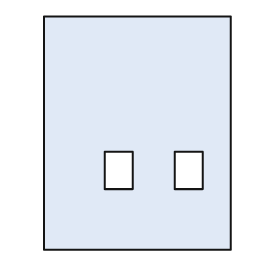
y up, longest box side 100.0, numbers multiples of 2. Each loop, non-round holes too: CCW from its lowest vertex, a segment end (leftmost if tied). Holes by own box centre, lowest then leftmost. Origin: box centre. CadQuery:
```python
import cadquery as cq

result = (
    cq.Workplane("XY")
    .moveTo(-40.0, -50.0)
    .lineTo(40.0, -50.0)
    .lineTo(40.0, 50.0)
    .lineTo(-40.0, 50.0)
    .close()
    .moveTo(-14.0, -24.0)
    .lineTo(-2.0, -24.0)
    .lineTo(-2.0, -8.0)
    .lineTo(-14.0, -8.0)
    .close()
    .moveTo(16.0, -24.0)
    .lineTo(28.0, -24.0)
    .lineTo(28.0, -8.0)
    .lineTo(16.0, -8.0)
    .close()
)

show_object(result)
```